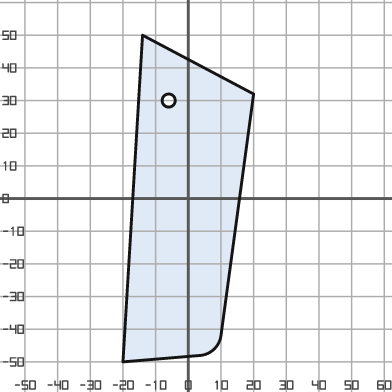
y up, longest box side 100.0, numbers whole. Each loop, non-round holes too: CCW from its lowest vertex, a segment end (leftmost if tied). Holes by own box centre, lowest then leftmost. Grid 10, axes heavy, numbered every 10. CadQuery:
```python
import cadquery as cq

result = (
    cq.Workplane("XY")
    .moveTo(-20.0, -50.0)
    .lineTo(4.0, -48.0)
    .threePointArc((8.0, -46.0), (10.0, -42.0))
    .lineTo(20.0, 32.0)
    .lineTo(-14.0, 50.0)
    .close()
    .moveTo(-6.0, 30.0)
    .circle(2.0)
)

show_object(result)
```